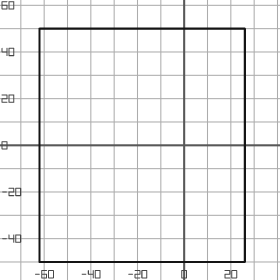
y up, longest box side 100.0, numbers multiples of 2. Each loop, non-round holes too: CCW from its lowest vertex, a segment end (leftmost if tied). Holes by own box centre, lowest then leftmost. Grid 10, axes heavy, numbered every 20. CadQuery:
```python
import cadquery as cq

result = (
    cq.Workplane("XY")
    .moveTo(-62.0, -50.0)
    .lineTo(26.0, -50.0)
    .lineTo(26.0, 50.0)
    .lineTo(-62.0, 50.0)
    .close()
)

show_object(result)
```